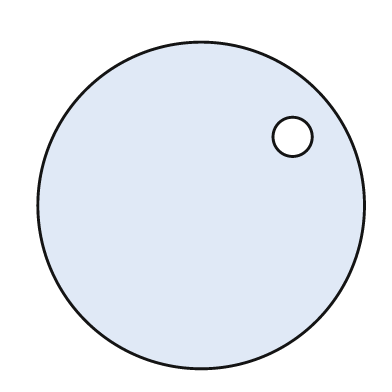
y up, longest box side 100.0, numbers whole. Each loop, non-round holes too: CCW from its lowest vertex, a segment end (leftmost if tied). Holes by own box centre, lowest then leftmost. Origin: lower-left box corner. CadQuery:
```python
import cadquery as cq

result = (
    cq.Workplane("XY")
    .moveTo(50.0, 50.0)
    .circle(50.0)
    .moveTo(78.0, 71.0)
    .circle(6.0)
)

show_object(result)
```